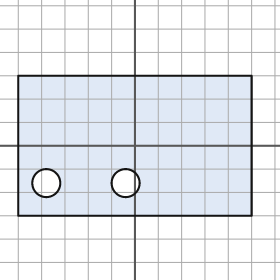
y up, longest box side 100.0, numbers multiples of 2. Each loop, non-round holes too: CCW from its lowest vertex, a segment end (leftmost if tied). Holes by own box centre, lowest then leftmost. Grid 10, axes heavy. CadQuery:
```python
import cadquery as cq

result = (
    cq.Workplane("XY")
    .moveTo(-50.0, -30.0)
    .lineTo(50.0, -30.0)
    .lineTo(50.0, 30.0)
    .lineTo(-50.0, 30.0)
    .close()
    .moveTo(-38.0, -16.0)
    .circle(6.0)
    .moveTo(-4.0, -16.0)
    .circle(6.0)
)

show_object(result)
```